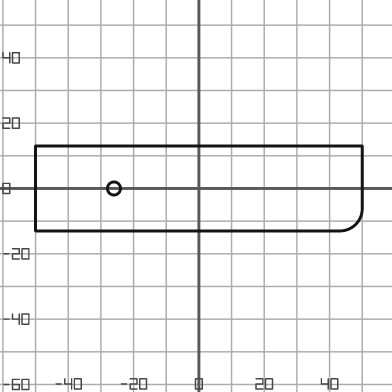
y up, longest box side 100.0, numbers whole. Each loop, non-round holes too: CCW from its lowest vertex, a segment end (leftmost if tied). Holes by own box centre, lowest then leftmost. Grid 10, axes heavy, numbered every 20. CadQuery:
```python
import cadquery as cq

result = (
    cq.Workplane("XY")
    .moveTo(-50.0, -13.0)
    .lineTo(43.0, -13.0)
    .threePointArc((48.0, -11.0), (50.0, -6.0))
    .lineTo(50.0, 13.0)
    .lineTo(-50.0, 13.0)
    .close()
    .moveTo(-26.0, 0.0)
    .circle(2.0)
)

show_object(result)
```